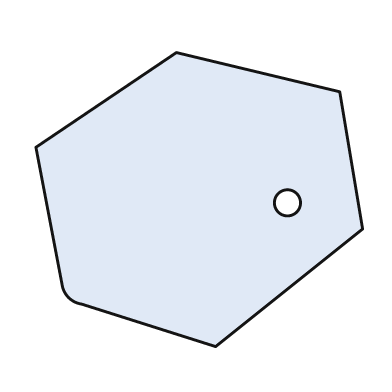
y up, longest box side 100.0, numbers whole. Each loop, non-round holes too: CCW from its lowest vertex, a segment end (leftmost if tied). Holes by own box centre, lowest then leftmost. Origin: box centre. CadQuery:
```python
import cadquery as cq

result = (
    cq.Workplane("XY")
    .moveTo(5.0, -45.0)
    .lineTo(50.0, -9.0)
    .lineTo(43.0, 33.0)
    .lineTo(-7.0, 45.0)
    .lineTo(-50.0, 16.0)
    .lineTo(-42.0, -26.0)
    .threePointArc((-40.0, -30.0), (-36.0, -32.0))
    .close()
    .moveTo(27.0, -1.0)
    .circle(4.0)
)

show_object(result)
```